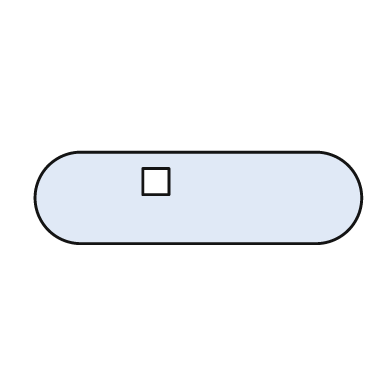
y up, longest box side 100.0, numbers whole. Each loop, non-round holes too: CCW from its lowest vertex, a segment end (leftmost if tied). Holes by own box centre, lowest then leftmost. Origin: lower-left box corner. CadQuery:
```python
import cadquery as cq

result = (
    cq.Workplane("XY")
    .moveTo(14.0, 0.0)
    .lineTo(86.0, 0.0)
    .threePointArc((100.0, 14.0), (86.0, 28.0))
    .lineTo(14.0, 28.0)
    .threePointArc((0.0, 14.0), (14.0, 0.0))
    .close()
    .moveTo(33.0, 15.0)
    .lineTo(41.0, 15.0)
    .lineTo(41.0, 23.0)
    .lineTo(33.0, 23.0)
    .close()
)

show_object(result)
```